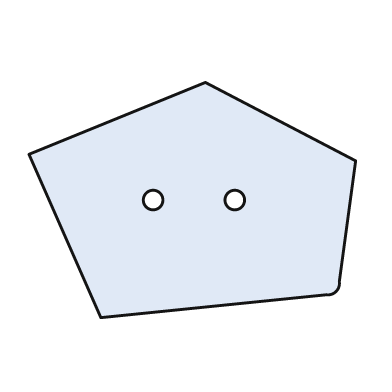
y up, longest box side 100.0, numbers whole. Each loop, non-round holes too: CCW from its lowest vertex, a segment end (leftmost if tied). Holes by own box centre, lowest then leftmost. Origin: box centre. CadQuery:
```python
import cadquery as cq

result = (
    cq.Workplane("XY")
    .moveTo(-28.0, -36.0)
    .lineTo(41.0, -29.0)
    .threePointArc((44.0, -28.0), (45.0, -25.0))
    .lineTo(50.0, 12.0)
    .lineTo(4.0, 36.0)
    .lineTo(-50.0, 14.0)
    .close()
    .moveTo(-12.0, 0.0)
    .circle(3.0)
    .moveTo(13.0, 0.0)
    .circle(3.0)
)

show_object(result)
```